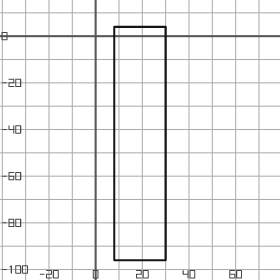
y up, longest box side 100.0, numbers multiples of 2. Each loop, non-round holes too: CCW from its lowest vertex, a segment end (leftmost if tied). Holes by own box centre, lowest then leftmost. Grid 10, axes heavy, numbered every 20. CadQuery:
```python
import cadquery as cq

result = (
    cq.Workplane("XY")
    .moveTo(8.0, -96.0)
    .lineTo(30.0, -96.0)
    .lineTo(30.0, 4.0)
    .lineTo(8.0, 4.0)
    .close()
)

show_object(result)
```